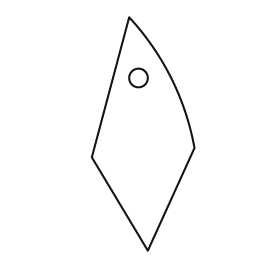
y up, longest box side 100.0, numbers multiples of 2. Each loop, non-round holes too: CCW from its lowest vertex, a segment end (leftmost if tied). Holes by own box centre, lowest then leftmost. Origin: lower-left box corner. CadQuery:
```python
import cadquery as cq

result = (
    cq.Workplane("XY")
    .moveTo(24.0, 0.0)
    .lineTo(44.0, 44.0)
    .threePointArc((34.0, 74.0), (16.0, 100.0))
    .lineTo(0.0, 40.0)
    .close()
    .moveTo(20.0, 74.0)
    .circle(4.0)
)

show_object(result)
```